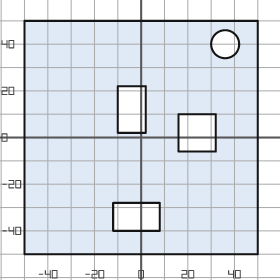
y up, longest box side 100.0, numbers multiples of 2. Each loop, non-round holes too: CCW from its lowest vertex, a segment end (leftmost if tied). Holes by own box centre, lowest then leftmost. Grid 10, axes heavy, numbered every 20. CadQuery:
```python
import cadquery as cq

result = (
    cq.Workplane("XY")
    .moveTo(-50.0, -50.0)
    .lineTo(50.0, -50.0)
    .lineTo(50.0, 50.0)
    .lineTo(-50.0, 50.0)
    .close()
    .moveTo(-12.0, -40.0)
    .lineTo(8.0, -40.0)
    .lineTo(8.0, -28.0)
    .lineTo(-12.0, -28.0)
    .close()
    .moveTo(16.0, -6.0)
    .lineTo(32.0, -6.0)
    .lineTo(32.0, 10.0)
    .lineTo(16.0, 10.0)
    .close()
    .moveTo(-10.0, 2.0)
    .lineTo(2.0, 2.0)
    .lineTo(2.0, 22.0)
    .lineTo(-10.0, 22.0)
    .close()
    .moveTo(36.0, 40.0)
    .circle(6.0)
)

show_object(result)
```